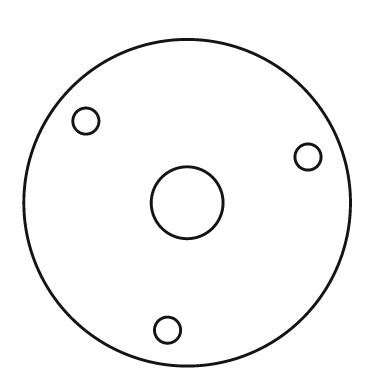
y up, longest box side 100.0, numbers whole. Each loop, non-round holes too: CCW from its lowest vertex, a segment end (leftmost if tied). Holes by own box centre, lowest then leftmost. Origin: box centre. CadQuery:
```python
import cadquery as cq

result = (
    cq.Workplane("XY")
    .moveTo(0.0, 0.0)
    .circle(50.0)
    .moveTo(-6.0, -39.0)
    .circle(4.0)
    .moveTo(0.0, 0.0)
    .circle(11.0)
    .moveTo(37.0, 14.0)
    .circle(4.0)
    .moveTo(-31.0, 25.0)
    .circle(4.0)
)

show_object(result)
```